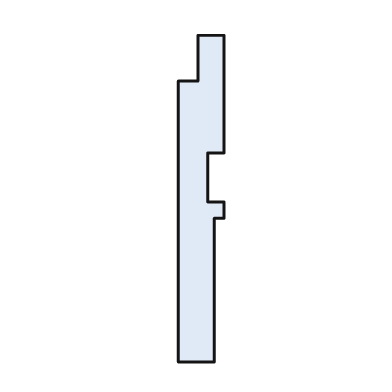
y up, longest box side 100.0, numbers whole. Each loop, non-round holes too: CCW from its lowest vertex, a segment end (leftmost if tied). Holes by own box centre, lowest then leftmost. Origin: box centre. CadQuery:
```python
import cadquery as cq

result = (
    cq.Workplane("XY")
    .moveTo(-7.0, -50.0)
    .lineTo(4.0, -50.0)
    .lineTo(4.0, -6.0)
    .lineTo(7.0, -6.0)
    .lineTo(7.0, -1.0)
    .lineTo(2.0, -1.0)
    .lineTo(2.0, 14.0)
    .lineTo(7.0, 14.0)
    .lineTo(7.0, 50.0)
    .lineTo(-1.0, 50.0)
    .lineTo(-1.0, 36.0)
    .lineTo(-7.0, 36.0)
    .close()
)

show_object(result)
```